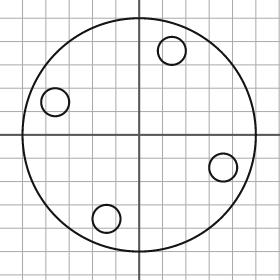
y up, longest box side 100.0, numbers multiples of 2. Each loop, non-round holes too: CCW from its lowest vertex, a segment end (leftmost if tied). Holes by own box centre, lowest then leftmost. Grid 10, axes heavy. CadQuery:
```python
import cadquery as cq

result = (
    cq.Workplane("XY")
    .moveTo(0.0, 0.0)
    .circle(50.0)
    .moveTo(-14.0, -36.0)
    .circle(6.0)
    .moveTo(36.0, -14.0)
    .circle(6.0)
    .moveTo(-36.0, 14.0)
    .circle(6.0)
    .moveTo(14.0, 36.0)
    .circle(6.0)
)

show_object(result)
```